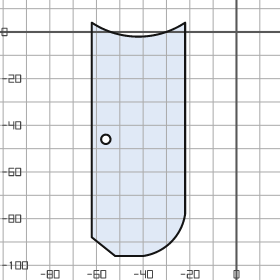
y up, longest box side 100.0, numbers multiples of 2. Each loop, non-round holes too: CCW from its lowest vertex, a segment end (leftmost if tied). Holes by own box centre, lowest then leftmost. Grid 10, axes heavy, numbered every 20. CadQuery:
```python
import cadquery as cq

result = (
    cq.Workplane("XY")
    .moveTo(-52.0, -96.0)
    .lineTo(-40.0, -96.0)
    .threePointArc((-28.0, -90.0), (-22.0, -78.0))
    .lineTo(-22.0, 4.0)
    .threePointArc((-42.0, -2.0), (-62.0, 4.0))
    .lineTo(-62.0, -88.0)
    .close()
    .moveTo(-56.0, -46.0)
    .circle(2.0)
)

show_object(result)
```